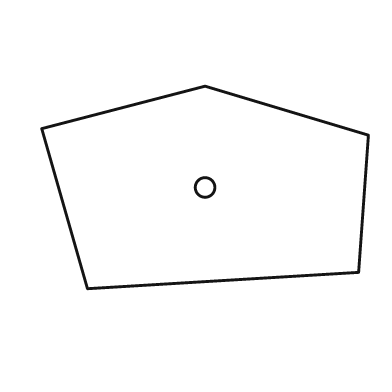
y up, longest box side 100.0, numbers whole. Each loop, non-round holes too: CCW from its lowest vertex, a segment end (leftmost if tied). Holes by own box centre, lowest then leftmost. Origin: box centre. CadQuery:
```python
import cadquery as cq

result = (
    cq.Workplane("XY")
    .moveTo(-36.0, -31.0)
    .lineTo(47.0, -26.0)
    .lineTo(50.0, 16.0)
    .lineTo(0.0, 31.0)
    .lineTo(-50.0, 18.0)
    .close()
    .moveTo(0.0, 0.0)
    .circle(3.0)
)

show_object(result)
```